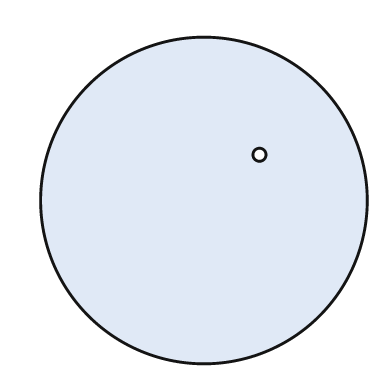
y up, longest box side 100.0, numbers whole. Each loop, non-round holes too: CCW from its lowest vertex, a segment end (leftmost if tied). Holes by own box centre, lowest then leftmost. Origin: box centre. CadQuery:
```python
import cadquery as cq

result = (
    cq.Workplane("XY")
    .moveTo(0.0, 0.0)
    .circle(50.0)
    .moveTo(17.0, 14.0)
    .circle(2.0)
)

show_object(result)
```